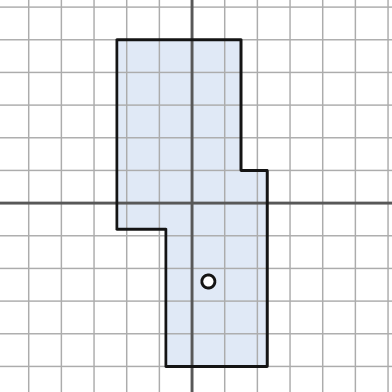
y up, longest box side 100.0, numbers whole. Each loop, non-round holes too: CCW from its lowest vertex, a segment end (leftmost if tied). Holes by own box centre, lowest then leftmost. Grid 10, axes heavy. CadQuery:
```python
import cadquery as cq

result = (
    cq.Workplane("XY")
    .moveTo(-8.0, -50.0)
    .lineTo(23.0, -50.0)
    .lineTo(23.0, 10.0)
    .lineTo(15.0, 10.0)
    .lineTo(15.0, 50.0)
    .lineTo(-23.0, 50.0)
    .lineTo(-23.0, -8.0)
    .lineTo(-8.0, -8.0)
    .close()
    .moveTo(5.0, -24.0)
    .circle(2.0)
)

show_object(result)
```